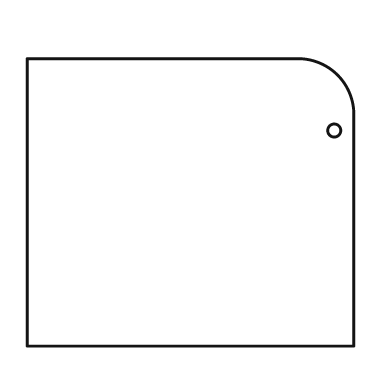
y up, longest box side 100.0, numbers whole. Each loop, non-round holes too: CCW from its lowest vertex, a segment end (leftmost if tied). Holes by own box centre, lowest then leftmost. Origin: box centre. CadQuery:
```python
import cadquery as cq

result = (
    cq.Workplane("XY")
    .moveTo(-50.0, -44.0)
    .lineTo(50.0, -44.0)
    .lineTo(50.0, 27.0)
    .threePointArc((45.0, 39.0), (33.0, 44.0))
    .lineTo(-50.0, 44.0)
    .close()
    .moveTo(44.0, 22.0)
    .circle(2.0)
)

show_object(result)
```